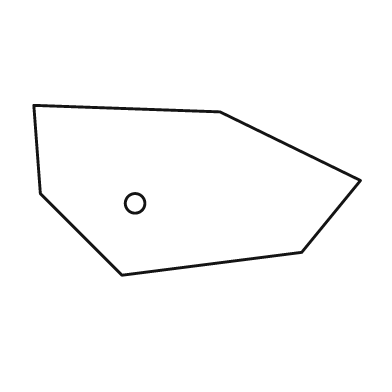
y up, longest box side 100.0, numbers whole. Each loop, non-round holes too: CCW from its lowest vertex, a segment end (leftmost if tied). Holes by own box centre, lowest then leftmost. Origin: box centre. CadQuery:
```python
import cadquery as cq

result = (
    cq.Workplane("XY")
    .moveTo(-23.0, -26.0)
    .lineTo(32.0, -19.0)
    .lineTo(50.0, 3.0)
    .lineTo(7.0, 24.0)
    .lineTo(-50.0, 26.0)
    .lineTo(-48.0, -1.0)
    .close()
    .moveTo(-19.0, -4.0)
    .circle(3.0)
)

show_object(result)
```